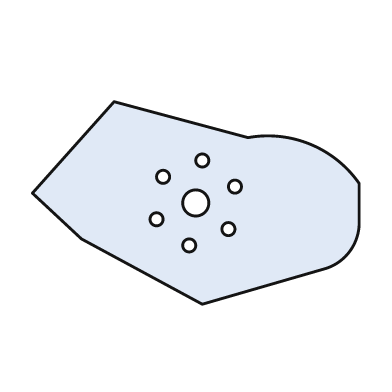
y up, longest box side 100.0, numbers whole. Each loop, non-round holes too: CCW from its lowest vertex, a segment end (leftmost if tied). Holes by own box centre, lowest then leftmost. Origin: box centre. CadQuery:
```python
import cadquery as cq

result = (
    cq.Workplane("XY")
    .moveTo(2.0, -31.0)
    .lineTo(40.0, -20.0)
    .threePointArc((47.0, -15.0), (50.0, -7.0))
    .lineTo(50.0, 6.0)
    .threePointArc((35.0, 18.0), (16.0, 20.0))
    .lineTo(-25.0, 31.0)
    .lineTo(-50.0, 3.0)
    .lineTo(-35.0, -11.0)
    .close()
    .moveTo(-2.0, -13.0)
    .circle(2.0)
    .moveTo(10.0, -8.0)
    .circle(2.0)
    .moveTo(-12.0, -5.0)
    .circle(2.0)
    .moveTo(0.0, 0.0)
    .circle(4.0)
    .moveTo(12.0, 5.0)
    .circle(2.0)
    .moveTo(-10.0, 8.0)
    .circle(2.0)
    .moveTo(2.0, 13.0)
    .circle(2.0)
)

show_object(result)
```